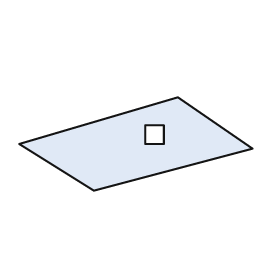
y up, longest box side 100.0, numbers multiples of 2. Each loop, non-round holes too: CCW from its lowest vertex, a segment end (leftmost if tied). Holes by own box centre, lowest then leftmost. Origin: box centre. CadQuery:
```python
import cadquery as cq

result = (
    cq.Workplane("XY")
    .moveTo(-18.0, -20.0)
    .lineTo(50.0, -2.0)
    .lineTo(18.0, 20.0)
    .lineTo(-50.0, 0.0)
    .close()
    .moveTo(4.0, 0.0)
    .lineTo(12.0, 0.0)
    .lineTo(12.0, 8.0)
    .lineTo(4.0, 8.0)
    .close()
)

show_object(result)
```